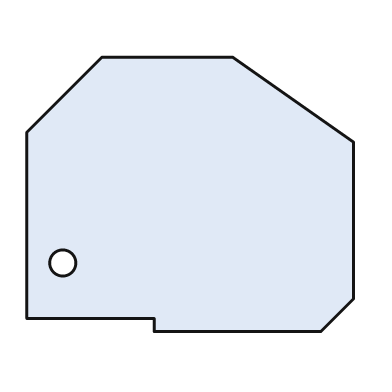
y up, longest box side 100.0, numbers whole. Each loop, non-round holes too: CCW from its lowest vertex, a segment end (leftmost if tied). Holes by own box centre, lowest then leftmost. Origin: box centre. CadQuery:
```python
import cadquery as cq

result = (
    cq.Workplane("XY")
    .moveTo(-11.0, -42.0)
    .lineTo(40.0, -42.0)
    .lineTo(50.0, -32.0)
    .lineTo(50.0, 16.0)
    .lineTo(13.0, 42.0)
    .lineTo(-27.0, 42.0)
    .lineTo(-50.0, 19.0)
    .lineTo(-50.0, -38.0)
    .lineTo(-11.0, -38.0)
    .close()
    .moveTo(-39.0, -21.0)
    .circle(4.0)
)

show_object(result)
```